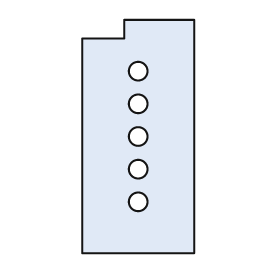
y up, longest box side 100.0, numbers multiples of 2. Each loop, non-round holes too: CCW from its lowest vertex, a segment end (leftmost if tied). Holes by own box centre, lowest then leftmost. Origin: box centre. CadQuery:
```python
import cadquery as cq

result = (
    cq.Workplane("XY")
    .moveTo(-24.0, -50.0)
    .lineTo(24.0, -50.0)
    .lineTo(24.0, 50.0)
    .lineTo(-6.0, 50.0)
    .lineTo(-6.0, 42.0)
    .lineTo(-24.0, 42.0)
    .close()
    .moveTo(0.0, -28.0)
    .circle(4.0)
    .moveTo(0.0, -14.0)
    .circle(4.0)
    .moveTo(0.0, 0.0)
    .circle(4.0)
    .moveTo(0.0, 14.0)
    .circle(4.0)
    .moveTo(0.0, 28.0)
    .circle(4.0)
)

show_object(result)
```